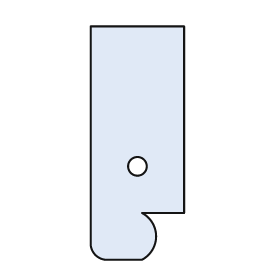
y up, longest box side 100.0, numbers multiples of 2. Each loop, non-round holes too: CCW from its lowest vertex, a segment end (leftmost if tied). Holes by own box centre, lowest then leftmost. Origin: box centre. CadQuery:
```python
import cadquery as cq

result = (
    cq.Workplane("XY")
    .moveTo(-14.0, -50.0)
    .lineTo(2.0, -50.0)
    .threePointArc((8.0, -40.0), (2.0, -30.0))
    .lineTo(20.0, -30.0)
    .lineTo(20.0, 50.0)
    .lineTo(-20.0, 50.0)
    .lineTo(-20.0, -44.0)
    .threePointArc((-18.0, -48.0), (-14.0, -50.0))
    .close()
    .moveTo(0.0, -10.0)
    .circle(4.0)
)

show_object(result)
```